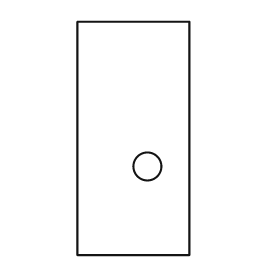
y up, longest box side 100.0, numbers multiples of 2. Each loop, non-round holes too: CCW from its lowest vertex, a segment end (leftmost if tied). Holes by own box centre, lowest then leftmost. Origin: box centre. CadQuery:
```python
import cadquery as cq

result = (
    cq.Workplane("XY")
    .moveTo(-24.0, -50.0)
    .lineTo(24.0, -50.0)
    .lineTo(24.0, 50.0)
    .lineTo(-24.0, 50.0)
    .close()
    .moveTo(6.0, -12.0)
    .circle(6.0)
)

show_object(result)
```